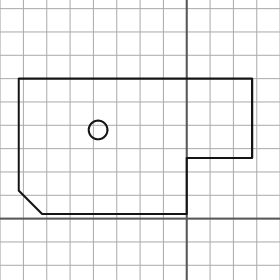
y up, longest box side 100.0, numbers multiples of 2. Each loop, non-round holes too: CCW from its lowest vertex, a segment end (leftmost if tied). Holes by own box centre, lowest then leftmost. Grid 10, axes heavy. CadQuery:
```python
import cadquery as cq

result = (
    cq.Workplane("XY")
    .moveTo(-62.0, 2.0)
    .lineTo(0.0, 2.0)
    .lineTo(0.0, 26.0)
    .lineTo(28.0, 26.0)
    .lineTo(28.0, 60.0)
    .lineTo(-72.0, 60.0)
    .lineTo(-72.0, 12.0)
    .close()
    .moveTo(-38.0, 38.0)
    .circle(4.0)
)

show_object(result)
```